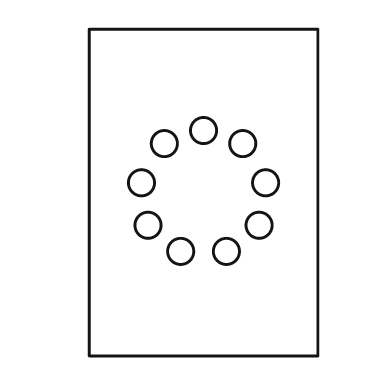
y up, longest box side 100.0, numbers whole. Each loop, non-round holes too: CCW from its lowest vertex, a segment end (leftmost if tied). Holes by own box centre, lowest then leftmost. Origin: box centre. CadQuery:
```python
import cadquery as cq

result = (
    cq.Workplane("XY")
    .moveTo(-35.0, -50.0)
    .lineTo(35.0, -50.0)
    .lineTo(35.0, 50.0)
    .lineTo(-35.0, 50.0)
    .close()
    .moveTo(-7.0, -18.0)
    .circle(4.0)
    .moveTo(7.0, -18.0)
    .circle(4.0)
    .moveTo(-17.0, -10.0)
    .circle(4.0)
    .moveTo(17.0, -10.0)
    .circle(4.0)
    .moveTo(-19.0, 3.0)
    .circle(4.0)
    .moveTo(19.0, 3.0)
    .circle(4.0)
    .moveTo(-12.0, 15.0)
    .circle(4.0)
    .moveTo(12.0, 15.0)
    .circle(4.0)
    .moveTo(0.0, 19.0)
    .circle(4.0)
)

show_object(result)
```